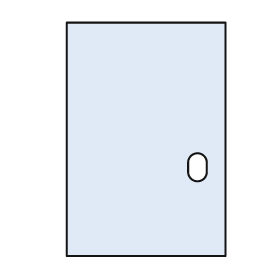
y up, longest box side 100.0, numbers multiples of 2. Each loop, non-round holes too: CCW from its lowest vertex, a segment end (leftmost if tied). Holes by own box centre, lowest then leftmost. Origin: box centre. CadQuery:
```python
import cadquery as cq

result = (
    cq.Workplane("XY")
    .moveTo(-34.0, -50.0)
    .lineTo(34.0, -50.0)
    .lineTo(34.0, 50.0)
    .lineTo(-34.0, 50.0)
    .close()
    .moveTo(18.0, -14.0)
    .threePointArc((22.0, -18.0), (26.0, -14.0))
    .lineTo(26.0, -10.0)
    .threePointArc((22.0, -6.0), (18.0, -10.0))
    .close()
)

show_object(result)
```